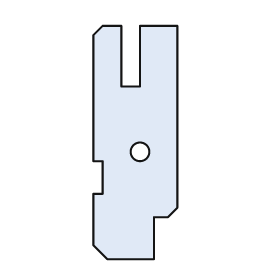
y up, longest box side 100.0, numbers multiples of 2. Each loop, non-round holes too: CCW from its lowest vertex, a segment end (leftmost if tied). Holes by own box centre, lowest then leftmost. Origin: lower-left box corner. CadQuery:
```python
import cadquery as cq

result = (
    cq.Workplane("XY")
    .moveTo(6.0, 0.0)
    .lineTo(26.0, 0.0)
    .lineTo(26.0, 18.0)
    .lineTo(32.0, 18.0)
    .lineTo(36.0, 22.0)
    .lineTo(36.0, 100.0)
    .lineTo(20.0, 100.0)
    .lineTo(20.0, 74.0)
    .lineTo(12.0, 74.0)
    .lineTo(12.0, 100.0)
    .lineTo(4.0, 100.0)
    .lineTo(0.0, 96.0)
    .lineTo(0.0, 42.0)
    .lineTo(4.0, 42.0)
    .lineTo(4.0, 28.0)
    .lineTo(0.0, 28.0)
    .lineTo(0.0, 6.0)
    .close()
    .moveTo(20.0, 46.0)
    .circle(4.0)
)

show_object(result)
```